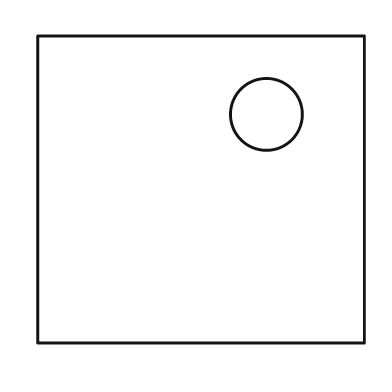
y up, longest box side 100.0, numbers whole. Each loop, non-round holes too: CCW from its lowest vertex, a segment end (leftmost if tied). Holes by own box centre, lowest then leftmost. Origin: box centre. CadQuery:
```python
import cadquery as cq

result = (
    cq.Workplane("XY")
    .moveTo(-50.0, -47.0)
    .lineTo(50.0, -47.0)
    .lineTo(50.0, 47.0)
    .lineTo(-50.0, 47.0)
    .close()
    .moveTo(20.0, 23.0)
    .circle(11.0)
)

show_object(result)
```